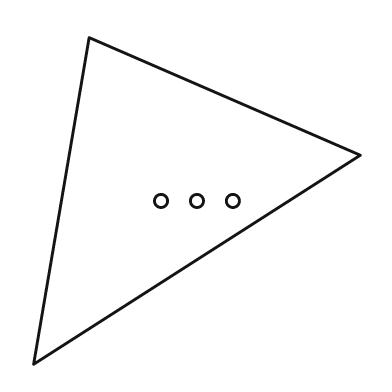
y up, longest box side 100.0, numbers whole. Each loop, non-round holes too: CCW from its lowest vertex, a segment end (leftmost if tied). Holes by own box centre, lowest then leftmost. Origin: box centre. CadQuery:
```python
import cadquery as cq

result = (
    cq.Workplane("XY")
    .moveTo(-50.0, -50.0)
    .lineTo(50.0, 14.0)
    .lineTo(-33.0, 50.0)
    .close()
    .moveTo(-11.0, 0.0)
    .circle(2.0)
    .moveTo(0.0, 0.0)
    .circle(2.0)
    .moveTo(11.0, 0.0)
    .circle(2.0)
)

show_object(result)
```